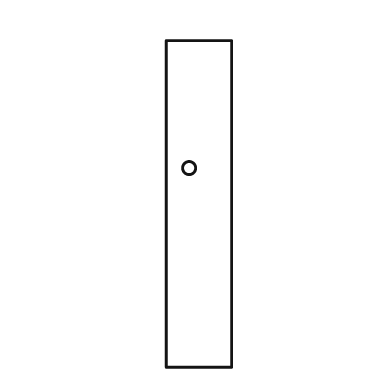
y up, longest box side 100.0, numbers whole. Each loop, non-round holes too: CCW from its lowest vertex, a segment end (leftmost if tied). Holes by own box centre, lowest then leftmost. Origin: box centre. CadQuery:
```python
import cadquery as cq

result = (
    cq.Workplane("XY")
    .moveTo(-10.0, -50.0)
    .lineTo(10.0, -50.0)
    .lineTo(10.0, 50.0)
    .lineTo(-10.0, 50.0)
    .close()
    .moveTo(-3.0, 11.0)
    .circle(2.0)
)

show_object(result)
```